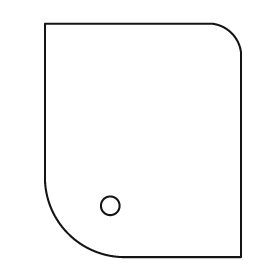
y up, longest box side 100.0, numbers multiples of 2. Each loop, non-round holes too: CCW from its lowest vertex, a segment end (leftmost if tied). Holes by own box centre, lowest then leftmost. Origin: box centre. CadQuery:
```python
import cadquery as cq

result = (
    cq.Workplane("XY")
    .moveTo(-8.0, -50.0)
    .lineTo(42.0, -50.0)
    .lineTo(42.0, 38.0)
    .threePointArc((38.0, 46.0), (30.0, 50.0))
    .lineTo(-42.0, 50.0)
    .lineTo(-42.0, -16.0)
    .threePointArc((-32.0, -40.0), (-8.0, -50.0))
    .close()
    .moveTo(-14.0, -28.0)
    .circle(4.0)
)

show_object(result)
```